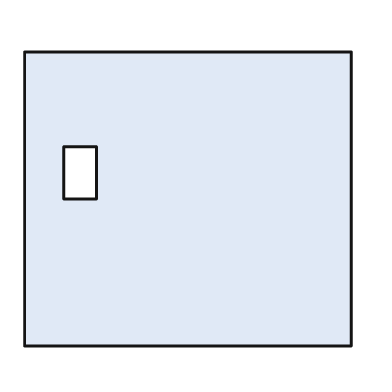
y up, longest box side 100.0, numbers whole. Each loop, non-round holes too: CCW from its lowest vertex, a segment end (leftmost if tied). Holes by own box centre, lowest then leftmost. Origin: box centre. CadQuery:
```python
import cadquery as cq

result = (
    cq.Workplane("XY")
    .moveTo(-50.0, -45.0)
    .lineTo(50.0, -45.0)
    .lineTo(50.0, 45.0)
    .lineTo(-50.0, 45.0)
    .close()
    .moveTo(-38.0, 0.0)
    .lineTo(-28.0, 0.0)
    .lineTo(-28.0, 16.0)
    .lineTo(-38.0, 16.0)
    .close()
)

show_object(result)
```